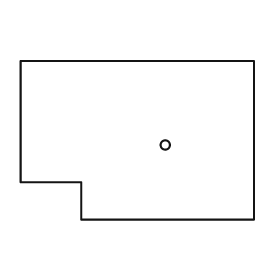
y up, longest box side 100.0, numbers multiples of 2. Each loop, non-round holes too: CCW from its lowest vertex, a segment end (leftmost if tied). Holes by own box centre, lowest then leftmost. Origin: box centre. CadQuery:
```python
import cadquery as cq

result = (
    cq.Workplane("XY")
    .moveTo(-24.0, -34.0)
    .lineTo(50.0, -34.0)
    .lineTo(50.0, 34.0)
    .lineTo(-50.0, 34.0)
    .lineTo(-50.0, -18.0)
    .lineTo(-24.0, -18.0)
    .close()
    .moveTo(12.0, -2.0)
    .circle(2.0)
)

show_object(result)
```